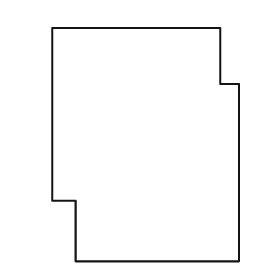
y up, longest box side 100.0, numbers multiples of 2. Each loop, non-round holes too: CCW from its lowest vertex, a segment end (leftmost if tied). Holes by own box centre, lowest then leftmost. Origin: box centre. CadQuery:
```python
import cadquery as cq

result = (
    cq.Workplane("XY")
    .moveTo(-30.0, -50.0)
    .lineTo(40.0, -50.0)
    .lineTo(40.0, 26.0)
    .lineTo(32.0, 26.0)
    .lineTo(32.0, 50.0)
    .lineTo(-40.0, 50.0)
    .lineTo(-40.0, -24.0)
    .lineTo(-30.0, -24.0)
    .close()
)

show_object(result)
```